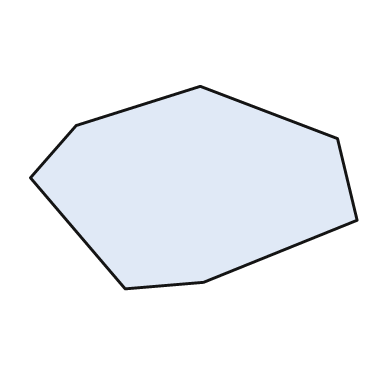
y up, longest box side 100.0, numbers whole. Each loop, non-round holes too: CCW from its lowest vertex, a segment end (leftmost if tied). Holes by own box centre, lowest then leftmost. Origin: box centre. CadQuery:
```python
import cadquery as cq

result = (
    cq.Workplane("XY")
    .moveTo(-21.0, -31.0)
    .lineTo(3.0, -29.0)
    .lineTo(50.0, -10.0)
    .lineTo(44.0, 15.0)
    .lineTo(2.0, 31.0)
    .lineTo(-36.0, 19.0)
    .lineTo(-50.0, 3.0)
    .close()
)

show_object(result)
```